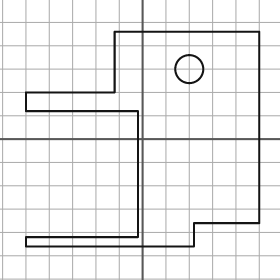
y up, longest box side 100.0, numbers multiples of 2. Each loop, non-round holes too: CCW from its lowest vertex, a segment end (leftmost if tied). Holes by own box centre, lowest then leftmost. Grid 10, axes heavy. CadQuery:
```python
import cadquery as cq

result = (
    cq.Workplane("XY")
    .moveTo(-50.0, -46.0)
    .lineTo(22.0, -46.0)
    .lineTo(22.0, -36.0)
    .lineTo(50.0, -36.0)
    .lineTo(50.0, 46.0)
    .lineTo(-12.0, 46.0)
    .lineTo(-12.0, 20.0)
    .lineTo(-50.0, 20.0)
    .lineTo(-50.0, 12.0)
    .lineTo(-2.0, 12.0)
    .lineTo(-2.0, -42.0)
    .lineTo(-50.0, -42.0)
    .close()
    .moveTo(20.0, 30.0)
    .circle(6.0)
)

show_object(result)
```